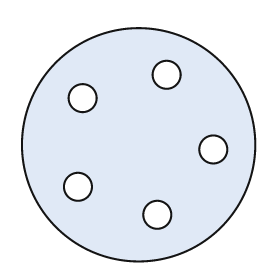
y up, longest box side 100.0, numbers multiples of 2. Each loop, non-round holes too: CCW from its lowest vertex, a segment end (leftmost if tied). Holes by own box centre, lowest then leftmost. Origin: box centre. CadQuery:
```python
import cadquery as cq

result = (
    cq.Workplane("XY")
    .moveTo(0.0, 0.0)
    .circle(50.0)
    .moveTo(8.0, -30.0)
    .circle(6.0)
    .moveTo(-26.0, -18.0)
    .circle(6.0)
    .moveTo(32.0, -2.0)
    .circle(6.0)
    .moveTo(-24.0, 20.0)
    .circle(6.0)
    .moveTo(12.0, 30.0)
    .circle(6.0)
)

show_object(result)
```